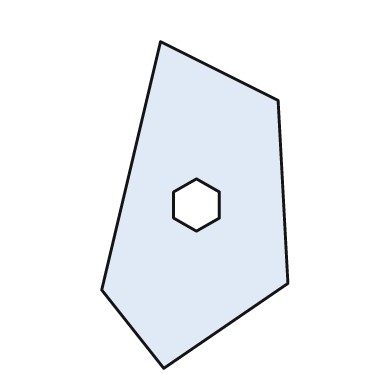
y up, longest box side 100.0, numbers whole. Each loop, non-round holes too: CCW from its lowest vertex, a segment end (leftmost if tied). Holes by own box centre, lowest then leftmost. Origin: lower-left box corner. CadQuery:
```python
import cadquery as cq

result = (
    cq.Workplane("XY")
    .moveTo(19.0, 0.0)
    .lineTo(57.0, 26.0)
    .lineTo(54.0, 82.0)
    .lineTo(18.0, 100.0)
    .lineTo(0.0, 24.0)
    .close()
    .moveTo(29.0, 42.0)
    .lineTo(36.0, 46.0)
    .lineTo(36.0, 54.0)
    .lineTo(29.0, 58.0)
    .lineTo(22.0, 54.0)
    .lineTo(22.0, 46.0)
    .close()
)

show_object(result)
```